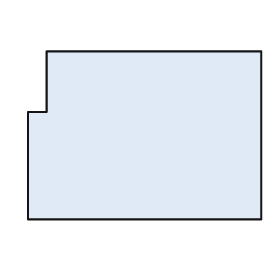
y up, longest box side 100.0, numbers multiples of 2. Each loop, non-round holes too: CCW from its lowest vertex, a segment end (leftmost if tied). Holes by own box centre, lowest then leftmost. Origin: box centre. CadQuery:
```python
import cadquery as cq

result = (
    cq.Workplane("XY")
    .moveTo(-50.0, -36.0)
    .lineTo(50.0, -36.0)
    .lineTo(50.0, 36.0)
    .lineTo(-42.0, 36.0)
    .lineTo(-42.0, 10.0)
    .lineTo(-50.0, 10.0)
    .close()
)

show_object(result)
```